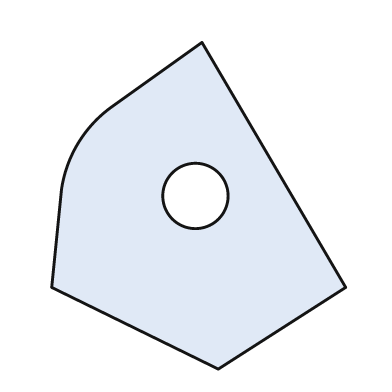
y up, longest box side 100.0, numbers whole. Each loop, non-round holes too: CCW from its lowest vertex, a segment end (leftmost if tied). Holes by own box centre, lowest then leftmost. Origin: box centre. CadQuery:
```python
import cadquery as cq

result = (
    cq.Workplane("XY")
    .moveTo(6.0, -50.0)
    .lineTo(45.0, -25.0)
    .lineTo(1.0, 50.0)
    .lineTo(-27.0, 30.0)
    .threePointArc((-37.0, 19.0), (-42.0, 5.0))
    .lineTo(-45.0, -25.0)
    .close()
    .moveTo(-1.0, 3.0)
    .circle(10.0)
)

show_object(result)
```